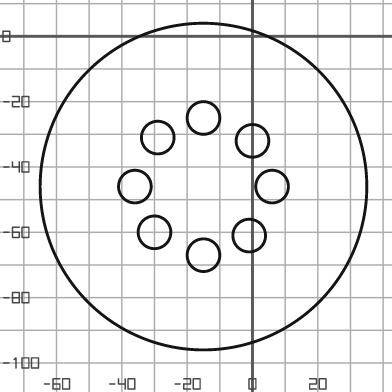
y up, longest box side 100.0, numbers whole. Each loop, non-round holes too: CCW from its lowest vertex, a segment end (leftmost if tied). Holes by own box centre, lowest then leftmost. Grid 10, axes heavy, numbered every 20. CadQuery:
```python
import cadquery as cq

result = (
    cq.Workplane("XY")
    .moveTo(-15.0, -46.0)
    .circle(50.0)
    .moveTo(-15.0, -67.0)
    .circle(5.0)
    .moveTo(-1.0, -61.0)
    .circle(5.0)
    .moveTo(-30.0, -60.0)
    .circle(5.0)
    .moveTo(-36.0, -46.0)
    .circle(5.0)
    .moveTo(6.0, -46.0)
    .circle(5.0)
    .moveTo(0.0, -32.0)
    .circle(5.0)
    .moveTo(-29.0, -31.0)
    .circle(5.0)
    .moveTo(-15.0, -25.0)
    .circle(5.0)
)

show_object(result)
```